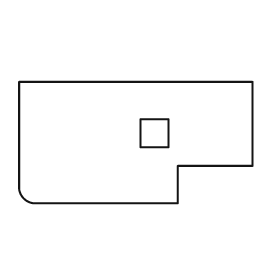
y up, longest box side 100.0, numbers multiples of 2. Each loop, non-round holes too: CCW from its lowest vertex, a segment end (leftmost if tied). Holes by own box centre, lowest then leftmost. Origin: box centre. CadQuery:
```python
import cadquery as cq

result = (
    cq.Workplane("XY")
    .moveTo(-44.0, -26.0)
    .lineTo(18.0, -26.0)
    .lineTo(18.0, -10.0)
    .lineTo(50.0, -10.0)
    .lineTo(50.0, 26.0)
    .lineTo(-50.0, 26.0)
    .lineTo(-50.0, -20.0)
    .threePointArc((-48.0, -24.0), (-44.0, -26.0))
    .close()
    .moveTo(2.0, -2.0)
    .lineTo(14.0, -2.0)
    .lineTo(14.0, 10.0)
    .lineTo(2.0, 10.0)
    .close()
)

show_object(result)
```